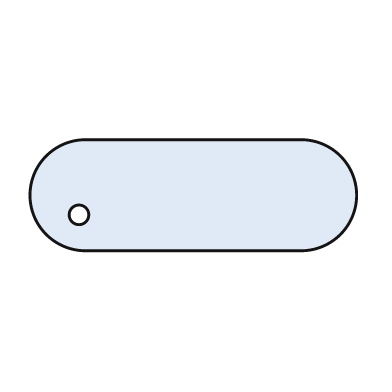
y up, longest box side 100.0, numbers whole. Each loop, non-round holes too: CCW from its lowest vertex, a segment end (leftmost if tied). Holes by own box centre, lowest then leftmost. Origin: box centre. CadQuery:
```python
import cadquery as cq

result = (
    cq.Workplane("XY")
    .moveTo(-33.0, -17.0)
    .lineTo(33.0, -17.0)
    .threePointArc((50.0, 0.0), (33.0, 17.0))
    .lineTo(-33.0, 17.0)
    .threePointArc((-50.0, 0.0), (-33.0, -17.0))
    .close()
    .moveTo(-35.0, -6.0)
    .circle(3.0)
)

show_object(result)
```